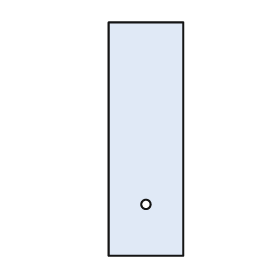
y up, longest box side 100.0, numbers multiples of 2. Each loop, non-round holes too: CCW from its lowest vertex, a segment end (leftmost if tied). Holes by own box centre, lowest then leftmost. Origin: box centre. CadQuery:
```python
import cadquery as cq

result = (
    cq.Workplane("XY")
    .moveTo(-16.0, -50.0)
    .lineTo(16.0, -50.0)
    .lineTo(16.0, 50.0)
    .lineTo(-16.0, 50.0)
    .close()
    .moveTo(0.0, -28.0)
    .circle(2.0)
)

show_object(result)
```